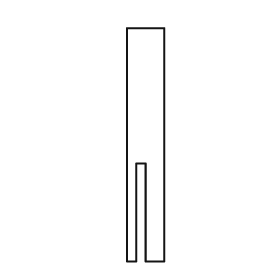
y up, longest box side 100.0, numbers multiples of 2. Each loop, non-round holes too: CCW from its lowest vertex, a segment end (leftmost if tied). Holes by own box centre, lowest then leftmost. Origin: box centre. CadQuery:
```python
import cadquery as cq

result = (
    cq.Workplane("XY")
    .moveTo(-8.0, -50.0)
    .lineTo(-4.0, -50.0)
    .lineTo(-4.0, -8.0)
    .lineTo(0.0, -8.0)
    .lineTo(0.0, -50.0)
    .lineTo(8.0, -50.0)
    .lineTo(8.0, 50.0)
    .lineTo(-8.0, 50.0)
    .close()
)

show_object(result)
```